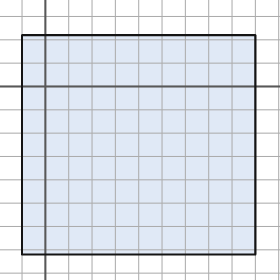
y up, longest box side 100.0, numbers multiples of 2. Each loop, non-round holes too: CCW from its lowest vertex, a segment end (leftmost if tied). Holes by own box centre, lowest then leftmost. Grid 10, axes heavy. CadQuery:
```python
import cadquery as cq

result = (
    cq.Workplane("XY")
    .moveTo(-10.0, -72.0)
    .lineTo(90.0, -72.0)
    .lineTo(90.0, 22.0)
    .lineTo(-10.0, 22.0)
    .close()
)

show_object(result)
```